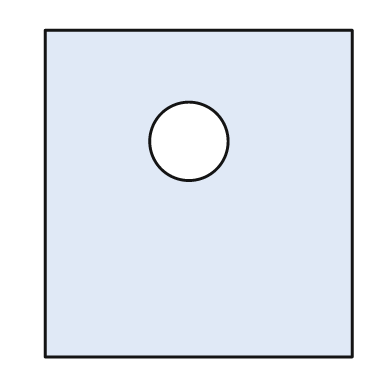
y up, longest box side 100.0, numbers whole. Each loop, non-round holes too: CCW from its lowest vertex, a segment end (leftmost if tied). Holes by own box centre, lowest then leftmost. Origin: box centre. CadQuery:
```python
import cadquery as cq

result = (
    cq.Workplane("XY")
    .moveTo(-47.0, -50.0)
    .lineTo(47.0, -50.0)
    .lineTo(47.0, 50.0)
    .lineTo(-47.0, 50.0)
    .close()
    .moveTo(-3.0, 16.0)
    .circle(12.0)
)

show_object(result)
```